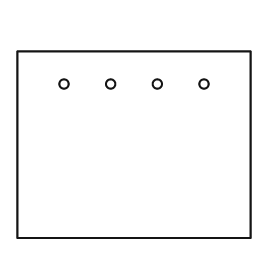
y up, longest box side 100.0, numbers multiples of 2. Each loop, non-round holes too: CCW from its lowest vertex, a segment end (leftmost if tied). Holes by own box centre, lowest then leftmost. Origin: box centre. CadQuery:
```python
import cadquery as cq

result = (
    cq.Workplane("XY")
    .moveTo(-50.0, -40.0)
    .lineTo(50.0, -40.0)
    .lineTo(50.0, 40.0)
    .lineTo(-50.0, 40.0)
    .close()
    .moveTo(-30.0, 26.0)
    .circle(2.0)
    .moveTo(-10.0, 26.0)
    .circle(2.0)
    .moveTo(10.0, 26.0)
    .circle(2.0)
    .moveTo(30.0, 26.0)
    .circle(2.0)
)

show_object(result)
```